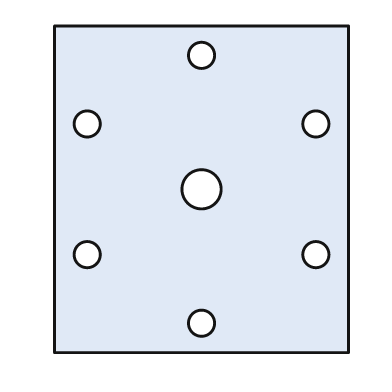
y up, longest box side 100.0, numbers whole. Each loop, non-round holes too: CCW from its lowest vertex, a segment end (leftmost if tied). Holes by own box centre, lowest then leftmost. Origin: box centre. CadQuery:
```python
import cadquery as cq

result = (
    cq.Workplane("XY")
    .moveTo(-45.0, -50.0)
    .lineTo(45.0, -50.0)
    .lineTo(45.0, 50.0)
    .lineTo(-45.0, 50.0)
    .close()
    .moveTo(0.0, -41.0)
    .circle(4.0)
    .moveTo(-35.0, -20.0)
    .circle(4.0)
    .moveTo(35.0, -20.0)
    .circle(4.0)
    .moveTo(0.0, 0.0)
    .circle(6.0)
    .moveTo(-35.0, 20.0)
    .circle(4.0)
    .moveTo(35.0, 20.0)
    .circle(4.0)
    .moveTo(0.0, 41.0)
    .circle(4.0)
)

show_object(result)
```